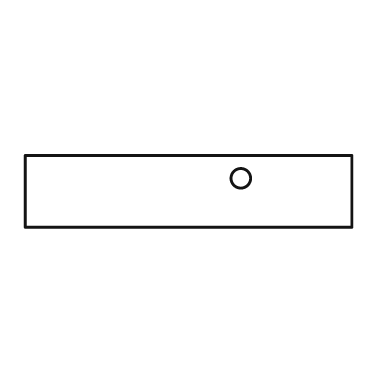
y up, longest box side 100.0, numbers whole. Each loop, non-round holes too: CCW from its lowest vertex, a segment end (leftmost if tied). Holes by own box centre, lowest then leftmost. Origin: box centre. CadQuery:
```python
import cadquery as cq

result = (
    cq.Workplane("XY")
    .moveTo(-50.0, -11.0)
    .lineTo(50.0, -11.0)
    .lineTo(50.0, 11.0)
    .lineTo(-50.0, 11.0)
    .close()
    .moveTo(16.0, 4.0)
    .circle(3.0)
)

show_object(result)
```